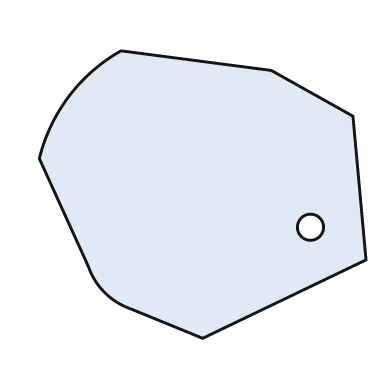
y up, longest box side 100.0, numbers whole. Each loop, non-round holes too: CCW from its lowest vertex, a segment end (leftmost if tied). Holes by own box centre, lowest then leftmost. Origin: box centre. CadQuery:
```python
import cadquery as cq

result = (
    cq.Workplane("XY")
    .moveTo(0.0, -44.0)
    .lineTo(50.0, -20.0)
    .lineTo(46.0, 24.0)
    .lineTo(21.0, 38.0)
    .lineTo(-25.0, 44.0)
    .threePointArc((-41.0, 30.0), (-50.0, 11.0))
    .lineTo(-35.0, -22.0)
    .threePointArc((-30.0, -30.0), (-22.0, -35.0))
    .close()
    .moveTo(33.0, -10.0)
    .circle(4.0)
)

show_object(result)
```